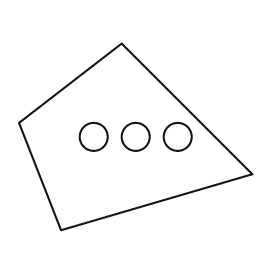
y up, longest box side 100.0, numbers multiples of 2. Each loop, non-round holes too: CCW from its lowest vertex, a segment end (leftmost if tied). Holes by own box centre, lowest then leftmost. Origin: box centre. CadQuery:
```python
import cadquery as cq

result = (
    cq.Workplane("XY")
    .moveTo(-32.0, -40.0)
    .lineTo(50.0, -16.0)
    .lineTo(-6.0, 40.0)
    .lineTo(-50.0, 6.0)
    .close()
    .moveTo(-18.0, 0.0)
    .circle(6.0)
    .moveTo(0.0, 0.0)
    .circle(6.0)
    .moveTo(18.0, 0.0)
    .circle(6.0)
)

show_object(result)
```